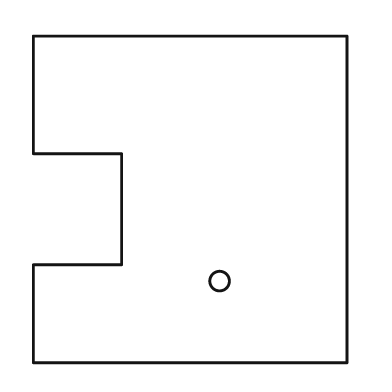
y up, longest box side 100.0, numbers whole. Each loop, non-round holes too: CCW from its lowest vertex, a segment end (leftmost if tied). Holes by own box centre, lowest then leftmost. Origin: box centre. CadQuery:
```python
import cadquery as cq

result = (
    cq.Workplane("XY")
    .moveTo(-48.0, -50.0)
    .lineTo(48.0, -50.0)
    .lineTo(48.0, 50.0)
    .lineTo(-48.0, 50.0)
    .lineTo(-48.0, 14.0)
    .lineTo(-21.0, 14.0)
    .lineTo(-21.0, -20.0)
    .lineTo(-48.0, -20.0)
    .close()
    .moveTo(9.0, -25.0)
    .circle(3.0)
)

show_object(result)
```